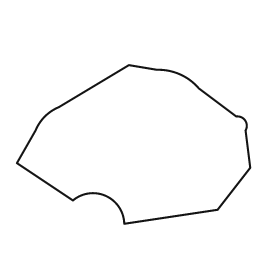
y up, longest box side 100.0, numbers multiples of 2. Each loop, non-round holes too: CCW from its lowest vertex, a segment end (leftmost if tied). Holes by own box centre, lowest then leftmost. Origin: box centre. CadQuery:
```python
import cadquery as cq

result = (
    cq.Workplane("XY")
    .moveTo(-4.0, -34.0)
    .lineTo(36.0, -28.0)
    .lineTo(50.0, -10.0)
    .lineTo(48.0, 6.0)
    .threePointArc((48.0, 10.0), (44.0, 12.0))
    .lineTo(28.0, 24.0)
    .threePointArc((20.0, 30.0), (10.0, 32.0))
    .lineTo(-2.0, 34.0)
    .lineTo(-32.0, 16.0)
    .threePointArc((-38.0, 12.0), (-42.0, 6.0))
    .lineTo(-50.0, -8.0)
    .lineTo(-26.0, -24.0)
    .threePointArc((-12.0, -22.0), (-4.0, -34.0))
    .close()
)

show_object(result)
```